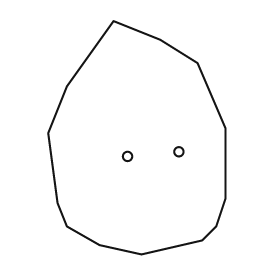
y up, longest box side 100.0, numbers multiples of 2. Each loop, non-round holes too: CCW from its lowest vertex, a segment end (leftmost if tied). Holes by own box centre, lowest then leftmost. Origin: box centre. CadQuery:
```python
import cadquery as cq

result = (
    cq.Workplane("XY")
    .moveTo(2.0, -50.0)
    .lineTo(28.0, -44.0)
    .lineTo(34.0, -38.0)
    .lineTo(38.0, -26.0)
    .lineTo(38.0, 4.0)
    .lineTo(26.0, 32.0)
    .lineTo(10.0, 42.0)
    .lineTo(-10.0, 50.0)
    .lineTo(-30.0, 22.0)
    .lineTo(-38.0, 2.0)
    .lineTo(-34.0, -28.0)
    .lineTo(-30.0, -38.0)
    .lineTo(-16.0, -46.0)
    .close()
    .moveTo(-4.0, -8.0)
    .circle(2.0)
    .moveTo(18.0, -6.0)
    .circle(2.0)
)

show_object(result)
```